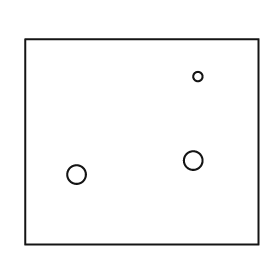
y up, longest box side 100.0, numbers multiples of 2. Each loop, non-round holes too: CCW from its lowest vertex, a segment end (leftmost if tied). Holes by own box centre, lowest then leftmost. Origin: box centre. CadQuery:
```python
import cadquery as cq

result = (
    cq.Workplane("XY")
    .moveTo(-50.0, -44.0)
    .lineTo(50.0, -44.0)
    .lineTo(50.0, 44.0)
    .lineTo(-50.0, 44.0)
    .close()
    .moveTo(-28.0, -14.0)
    .circle(4.0)
    .moveTo(22.0, -8.0)
    .circle(4.0)
    .moveTo(24.0, 28.0)
    .circle(2.0)
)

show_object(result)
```